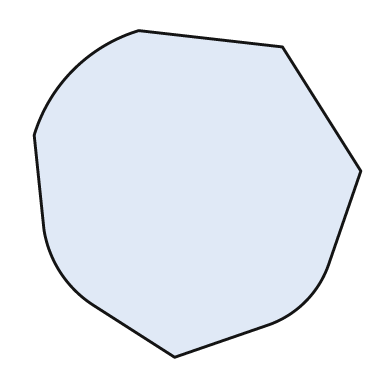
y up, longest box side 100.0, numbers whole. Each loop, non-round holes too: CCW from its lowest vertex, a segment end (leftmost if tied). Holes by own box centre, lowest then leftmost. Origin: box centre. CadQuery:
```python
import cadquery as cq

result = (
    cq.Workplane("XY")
    .moveTo(-7.0, -50.0)
    .lineTo(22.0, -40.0)
    .threePointArc((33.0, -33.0), (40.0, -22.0))
    .lineTo(50.0, 7.0)
    .lineTo(26.0, 45.0)
    .lineTo(-18.0, 50.0)
    .threePointArc((-38.0, 38.0), (-50.0, 18.0))
    .lineTo(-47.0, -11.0)
    .threePointArc((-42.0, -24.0), (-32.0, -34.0))
    .close()
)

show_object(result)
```